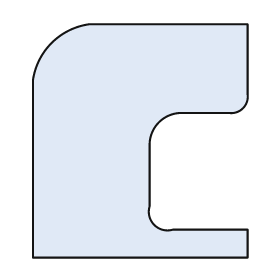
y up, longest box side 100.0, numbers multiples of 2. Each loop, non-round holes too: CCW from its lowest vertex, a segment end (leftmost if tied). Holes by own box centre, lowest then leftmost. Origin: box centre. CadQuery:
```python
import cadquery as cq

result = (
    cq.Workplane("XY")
    .moveTo(-46.0, -50.0)
    .lineTo(46.0, -50.0)
    .lineTo(46.0, -38.0)
    .lineTo(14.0, -38.0)
    .threePointArc((6.0, -36.0), (4.0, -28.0))
    .lineTo(4.0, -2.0)
    .threePointArc((8.0, 8.0), (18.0, 12.0))
    .lineTo(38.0, 12.0)
    .threePointArc((44.0, 14.0), (46.0, 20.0))
    .lineTo(46.0, 50.0)
    .lineTo(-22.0, 50.0)
    .threePointArc((-38.0, 42.0), (-46.0, 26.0))
    .close()
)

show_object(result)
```